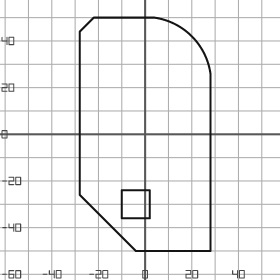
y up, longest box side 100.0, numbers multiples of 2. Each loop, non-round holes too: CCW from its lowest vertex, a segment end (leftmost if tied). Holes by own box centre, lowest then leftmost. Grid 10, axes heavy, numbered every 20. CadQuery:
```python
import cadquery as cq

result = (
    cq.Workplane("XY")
    .moveTo(-4.0, -50.0)
    .lineTo(28.0, -50.0)
    .lineTo(28.0, 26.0)
    .threePointArc((20.0, 42.0), (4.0, 50.0))
    .lineTo(-22.0, 50.0)
    .lineTo(-28.0, 44.0)
    .lineTo(-28.0, -26.0)
    .close()
    .moveTo(-10.0, -36.0)
    .lineTo(2.0, -36.0)
    .lineTo(2.0, -24.0)
    .lineTo(-10.0, -24.0)
    .close()
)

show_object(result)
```